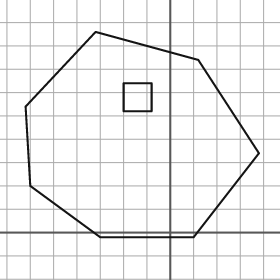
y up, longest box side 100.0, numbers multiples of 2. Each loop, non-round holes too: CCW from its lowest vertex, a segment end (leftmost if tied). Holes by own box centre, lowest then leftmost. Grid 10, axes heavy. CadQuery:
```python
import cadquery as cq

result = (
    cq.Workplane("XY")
    .moveTo(-30.0, -2.0)
    .lineTo(10.0, -2.0)
    .lineTo(38.0, 34.0)
    .lineTo(12.0, 74.0)
    .lineTo(-32.0, 86.0)
    .lineTo(-62.0, 54.0)
    .lineTo(-60.0, 20.0)
    .close()
    .moveTo(-20.0, 52.0)
    .lineTo(-8.0, 52.0)
    .lineTo(-8.0, 64.0)
    .lineTo(-20.0, 64.0)
    .close()
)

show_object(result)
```